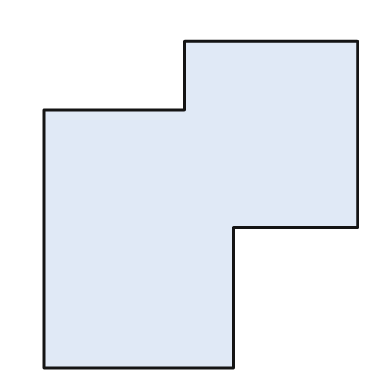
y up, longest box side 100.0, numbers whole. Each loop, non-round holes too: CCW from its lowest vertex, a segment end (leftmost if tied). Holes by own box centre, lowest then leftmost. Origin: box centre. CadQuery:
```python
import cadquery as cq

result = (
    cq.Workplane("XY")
    .moveTo(-48.0, -50.0)
    .lineTo(10.0, -50.0)
    .lineTo(10.0, -7.0)
    .lineTo(48.0, -7.0)
    .lineTo(48.0, 50.0)
    .lineTo(-5.0, 50.0)
    .lineTo(-5.0, 29.0)
    .lineTo(-48.0, 29.0)
    .close()
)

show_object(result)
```